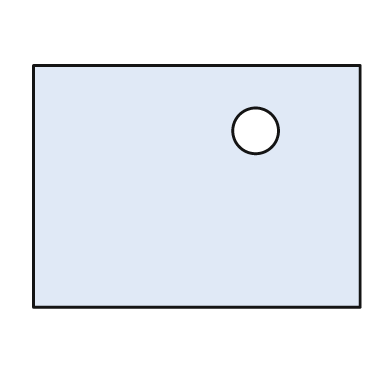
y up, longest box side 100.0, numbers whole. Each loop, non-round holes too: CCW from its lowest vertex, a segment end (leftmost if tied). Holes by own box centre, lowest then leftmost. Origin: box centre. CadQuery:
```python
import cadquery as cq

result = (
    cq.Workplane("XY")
    .moveTo(-50.0, -37.0)
    .lineTo(50.0, -37.0)
    .lineTo(50.0, 37.0)
    .lineTo(-50.0, 37.0)
    .close()
    .moveTo(18.0, 17.0)
    .circle(7.0)
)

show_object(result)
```